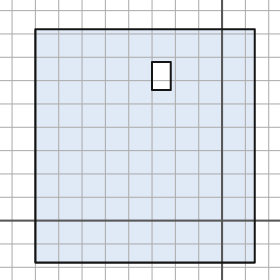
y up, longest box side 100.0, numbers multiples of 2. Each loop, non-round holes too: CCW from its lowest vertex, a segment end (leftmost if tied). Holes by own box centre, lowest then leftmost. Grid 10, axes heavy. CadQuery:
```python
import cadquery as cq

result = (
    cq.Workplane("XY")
    .moveTo(-80.0, -18.0)
    .lineTo(14.0, -18.0)
    .lineTo(14.0, 82.0)
    .lineTo(-80.0, 82.0)
    .close()
    .moveTo(-30.0, 56.0)
    .lineTo(-22.0, 56.0)
    .lineTo(-22.0, 68.0)
    .lineTo(-30.0, 68.0)
    .close()
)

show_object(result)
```